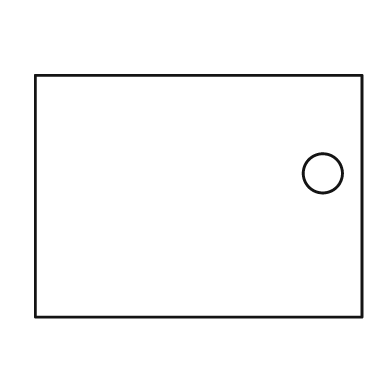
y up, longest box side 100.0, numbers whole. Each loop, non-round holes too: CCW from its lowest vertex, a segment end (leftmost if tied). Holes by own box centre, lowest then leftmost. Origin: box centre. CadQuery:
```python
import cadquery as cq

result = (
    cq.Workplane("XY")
    .moveTo(-50.0, -37.0)
    .lineTo(50.0, -37.0)
    .lineTo(50.0, 37.0)
    .lineTo(-50.0, 37.0)
    .close()
    .moveTo(38.0, 7.0)
    .circle(6.0)
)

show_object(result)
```